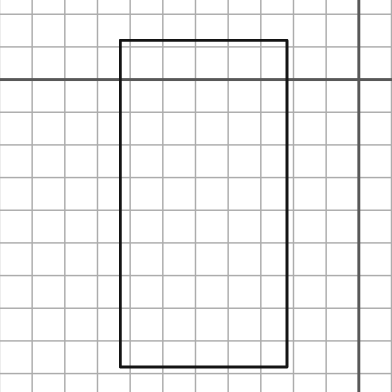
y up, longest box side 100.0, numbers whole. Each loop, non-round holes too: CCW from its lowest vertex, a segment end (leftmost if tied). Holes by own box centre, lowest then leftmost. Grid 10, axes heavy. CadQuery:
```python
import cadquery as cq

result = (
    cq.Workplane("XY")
    .moveTo(-73.0, -88.0)
    .lineTo(-22.0, -88.0)
    .lineTo(-22.0, 12.0)
    .lineTo(-73.0, 12.0)
    .close()
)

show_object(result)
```